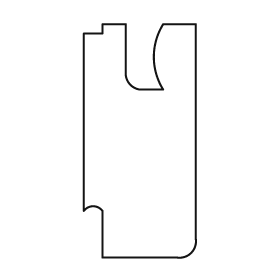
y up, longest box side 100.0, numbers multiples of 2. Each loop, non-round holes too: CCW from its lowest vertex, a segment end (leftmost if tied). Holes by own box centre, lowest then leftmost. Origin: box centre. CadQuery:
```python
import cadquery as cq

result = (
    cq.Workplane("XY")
    .moveTo(-16.0, -50.0)
    .lineTo(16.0, -50.0)
    .threePointArc((22.0, -48.0), (24.0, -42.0))
    .lineTo(24.0, 50.0)
    .lineTo(10.0, 50.0)
    .threePointArc((6.0, 36.0), (10.0, 22.0))
    .lineTo(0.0, 22.0)
    .threePointArc((-4.0, 24.0), (-6.0, 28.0))
    .lineTo(-6.0, 50.0)
    .lineTo(-16.0, 50.0)
    .lineTo(-16.0, 46.0)
    .lineTo(-24.0, 46.0)
    .lineTo(-24.0, -30.0)
    .threePointArc((-20.0, -28.0), (-16.0, -30.0))
    .close()
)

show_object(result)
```